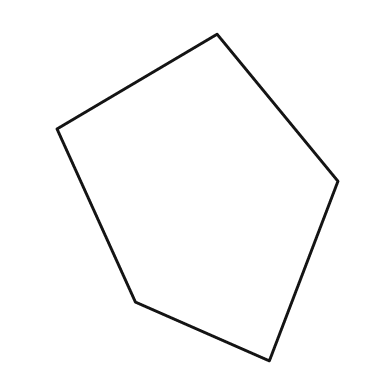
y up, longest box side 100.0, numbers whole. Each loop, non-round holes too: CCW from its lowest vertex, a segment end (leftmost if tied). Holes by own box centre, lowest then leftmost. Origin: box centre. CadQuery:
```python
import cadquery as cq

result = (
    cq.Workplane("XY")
    .moveTo(22.0, -50.0)
    .lineTo(43.0, 5.0)
    .lineTo(6.0, 50.0)
    .lineTo(-43.0, 21.0)
    .lineTo(-19.0, -32.0)
    .close()
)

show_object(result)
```